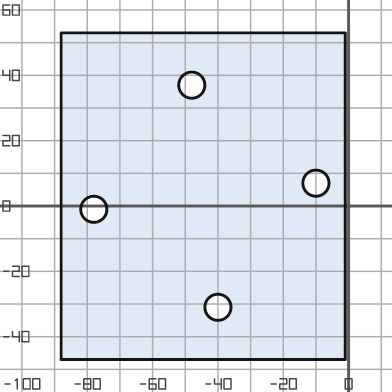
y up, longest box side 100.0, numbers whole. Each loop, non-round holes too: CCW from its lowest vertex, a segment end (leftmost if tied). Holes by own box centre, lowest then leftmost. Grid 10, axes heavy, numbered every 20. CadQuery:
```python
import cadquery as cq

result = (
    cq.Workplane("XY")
    .moveTo(-88.0, -47.0)
    .lineTo(-1.0, -47.0)
    .lineTo(-1.0, 53.0)
    .lineTo(-88.0, 53.0)
    .close()
    .moveTo(-40.0, -31.0)
    .circle(4.0)
    .moveTo(-78.0, -1.0)
    .circle(4.0)
    .moveTo(-10.0, 7.0)
    .circle(4.0)
    .moveTo(-48.0, 37.0)
    .circle(4.0)
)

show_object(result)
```